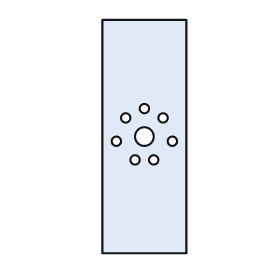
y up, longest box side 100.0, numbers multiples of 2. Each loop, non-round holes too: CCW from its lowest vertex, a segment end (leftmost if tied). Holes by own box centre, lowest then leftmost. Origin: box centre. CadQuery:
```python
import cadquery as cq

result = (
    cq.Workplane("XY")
    .moveTo(-18.0, -50.0)
    .lineTo(18.0, -50.0)
    .lineTo(18.0, 50.0)
    .lineTo(-18.0, 50.0)
    .close()
    .moveTo(-4.0, -10.0)
    .circle(2.0)
    .moveTo(4.0, -10.0)
    .circle(2.0)
    .moveTo(-12.0, -2.0)
    .circle(2.0)
    .moveTo(12.0, -2.0)
    .circle(2.0)
    .moveTo(0.0, 0.0)
    .circle(4.0)
    .moveTo(-8.0, 8.0)
    .circle(2.0)
    .moveTo(8.0, 8.0)
    .circle(2.0)
    .moveTo(0.0, 12.0)
    .circle(2.0)
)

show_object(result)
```